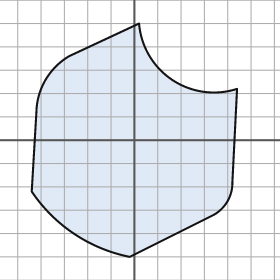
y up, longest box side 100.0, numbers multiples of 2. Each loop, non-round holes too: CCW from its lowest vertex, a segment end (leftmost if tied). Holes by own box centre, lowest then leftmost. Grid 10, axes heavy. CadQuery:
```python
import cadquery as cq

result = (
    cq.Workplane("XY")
    .moveTo(-2.0, -50.0)
    .lineTo(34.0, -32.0)
    .threePointArc((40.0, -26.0), (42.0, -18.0))
    .lineTo(44.0, 22.0)
    .threePointArc((16.0, 26.0), (2.0, 50.0))
    .lineTo(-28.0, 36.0)
    .threePointArc((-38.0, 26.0), (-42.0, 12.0))
    .lineTo(-44.0, -22.0)
    .threePointArc((-26.0, -40.0), (-2.0, -50.0))
    .close()
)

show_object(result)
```